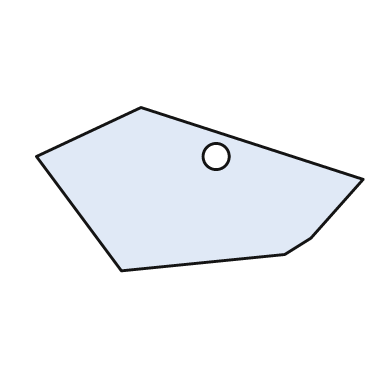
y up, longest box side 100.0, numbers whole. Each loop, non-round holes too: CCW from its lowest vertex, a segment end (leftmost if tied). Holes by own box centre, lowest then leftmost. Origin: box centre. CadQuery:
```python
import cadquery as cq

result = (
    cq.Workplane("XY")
    .moveTo(-24.0, -25.0)
    .lineTo(26.0, -20.0)
    .lineTo(34.0, -15.0)
    .lineTo(50.0, 3.0)
    .lineTo(-18.0, 25.0)
    .lineTo(-50.0, 10.0)
    .close()
    .moveTo(5.0, 10.0)
    .circle(4.0)
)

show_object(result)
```